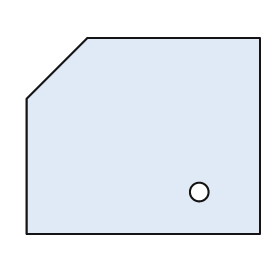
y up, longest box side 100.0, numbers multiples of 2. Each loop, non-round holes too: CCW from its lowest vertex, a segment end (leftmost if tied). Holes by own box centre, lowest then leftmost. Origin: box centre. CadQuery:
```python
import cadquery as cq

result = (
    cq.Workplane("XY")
    .moveTo(-50.0, -42.0)
    .lineTo(50.0, -42.0)
    .lineTo(50.0, 42.0)
    .lineTo(-24.0, 42.0)
    .lineTo(-50.0, 16.0)
    .close()
    .moveTo(24.0, -24.0)
    .circle(4.0)
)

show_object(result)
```